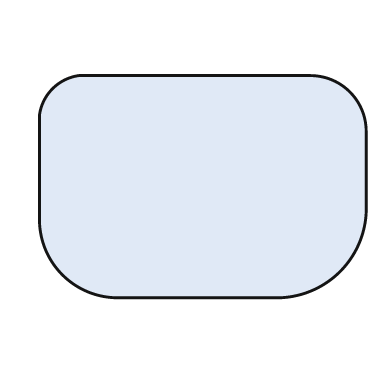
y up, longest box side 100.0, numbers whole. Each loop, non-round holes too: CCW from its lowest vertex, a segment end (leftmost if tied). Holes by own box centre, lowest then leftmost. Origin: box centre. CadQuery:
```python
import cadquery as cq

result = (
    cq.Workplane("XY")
    .moveTo(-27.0, -34.0)
    .lineTo(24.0, -34.0)
    .threePointArc((42.0, -26.0), (50.0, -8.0))
    .lineTo(50.0, 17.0)
    .threePointArc((45.0, 29.0), (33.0, 34.0))
    .lineTo(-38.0, 34.0)
    .threePointArc((-46.0, 30.0), (-50.0, 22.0))
    .lineTo(-50.0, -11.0)
    .threePointArc((-43.0, -27.0), (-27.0, -34.0))
    .close()
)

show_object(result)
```